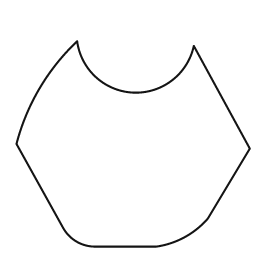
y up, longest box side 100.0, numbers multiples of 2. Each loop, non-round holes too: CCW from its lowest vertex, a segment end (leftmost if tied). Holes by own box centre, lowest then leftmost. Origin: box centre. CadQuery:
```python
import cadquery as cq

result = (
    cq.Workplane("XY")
    .moveTo(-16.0, -44.0)
    .lineTo(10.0, -44.0)
    .threePointArc((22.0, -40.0), (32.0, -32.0))
    .lineTo(50.0, -2.0)
    .lineTo(26.0, 42.0)
    .threePointArc((0.0, 22.0), (-24.0, 44.0))
    .threePointArc((-40.0, 24.0), (-50.0, 0.0))
    .lineTo(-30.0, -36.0)
    .threePointArc((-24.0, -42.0), (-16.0, -44.0))
    .close()
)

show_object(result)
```